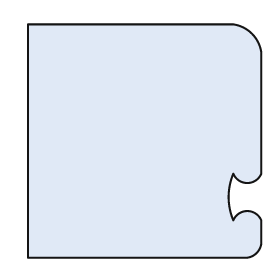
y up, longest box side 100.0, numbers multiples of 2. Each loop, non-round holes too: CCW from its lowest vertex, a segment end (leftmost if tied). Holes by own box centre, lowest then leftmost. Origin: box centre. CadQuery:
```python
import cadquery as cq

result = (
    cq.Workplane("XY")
    .moveTo(-50.0, -50.0)
    .lineTo(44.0, -50.0)
    .threePointArc((48.0, -48.0), (50.0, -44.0))
    .lineTo(50.0, -34.0)
    .threePointArc((44.0, -30.0), (38.0, -34.0))
    .threePointArc((36.0, -24.0), (38.0, -14.0))
    .threePointArc((44.0, -18.0), (50.0, -14.0))
    .lineTo(50.0, 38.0)
    .threePointArc((46.0, 46.0), (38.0, 50.0))
    .lineTo(-50.0, 50.0)
    .close()
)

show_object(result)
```